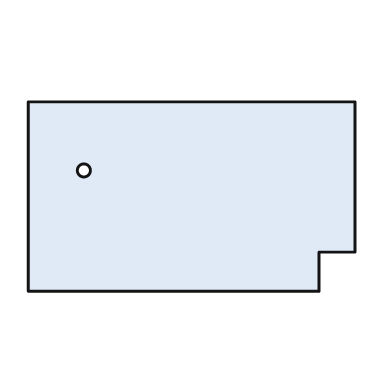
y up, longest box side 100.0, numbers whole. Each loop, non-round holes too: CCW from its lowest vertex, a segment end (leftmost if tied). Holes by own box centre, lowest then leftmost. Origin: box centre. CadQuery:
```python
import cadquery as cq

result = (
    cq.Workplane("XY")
    .moveTo(-50.0, -29.0)
    .lineTo(39.0, -29.0)
    .lineTo(39.0, -17.0)
    .lineTo(50.0, -17.0)
    .lineTo(50.0, 29.0)
    .lineTo(-50.0, 29.0)
    .close()
    .moveTo(-33.0, 8.0)
    .circle(2.0)
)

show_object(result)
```